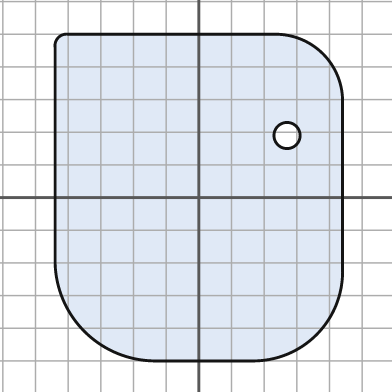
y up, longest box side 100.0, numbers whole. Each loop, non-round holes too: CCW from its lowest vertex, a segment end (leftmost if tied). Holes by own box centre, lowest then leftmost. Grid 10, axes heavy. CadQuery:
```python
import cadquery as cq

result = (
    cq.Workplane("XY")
    .moveTo(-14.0, -50.0)
    .lineTo(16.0, -50.0)
    .threePointArc((36.0, -42.0), (44.0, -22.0))
    .lineTo(44.0, 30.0)
    .threePointArc((38.0, 44.0), (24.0, 50.0))
    .lineTo(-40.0, 50.0)
    .threePointArc((-43.0, 49.0), (-44.0, 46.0))
    .lineTo(-44.0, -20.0)
    .threePointArc((-35.0, -41.0), (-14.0, -50.0))
    .close()
    .moveTo(27.0, 19.0)
    .circle(4.0)
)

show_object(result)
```